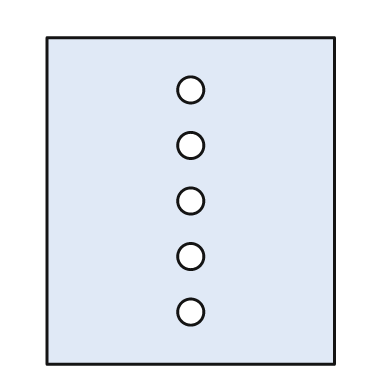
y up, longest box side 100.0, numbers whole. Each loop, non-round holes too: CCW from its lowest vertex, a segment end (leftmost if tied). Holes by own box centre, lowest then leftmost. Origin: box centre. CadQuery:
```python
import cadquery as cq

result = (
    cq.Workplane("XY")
    .moveTo(-44.0, -50.0)
    .lineTo(44.0, -50.0)
    .lineTo(44.0, 50.0)
    .lineTo(-44.0, 50.0)
    .close()
    .moveTo(0.0, -34.0)
    .circle(4.0)
    .moveTo(0.0, -17.0)
    .circle(4.0)
    .moveTo(0.0, 0.0)
    .circle(4.0)
    .moveTo(0.0, 17.0)
    .circle(4.0)
    .moveTo(0.0, 34.0)
    .circle(4.0)
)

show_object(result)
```